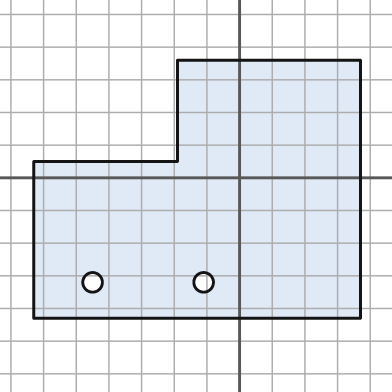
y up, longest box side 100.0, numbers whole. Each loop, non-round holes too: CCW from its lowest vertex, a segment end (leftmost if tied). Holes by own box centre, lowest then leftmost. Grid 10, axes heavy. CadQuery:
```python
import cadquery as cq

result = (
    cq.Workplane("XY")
    .moveTo(-63.0, -43.0)
    .lineTo(37.0, -43.0)
    .lineTo(37.0, 36.0)
    .lineTo(-19.0, 36.0)
    .lineTo(-19.0, 5.0)
    .lineTo(-63.0, 5.0)
    .close()
    .moveTo(-45.0, -32.0)
    .circle(3.0)
    .moveTo(-11.0, -32.0)
    .circle(3.0)
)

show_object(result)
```